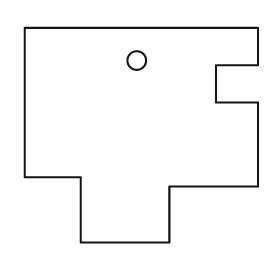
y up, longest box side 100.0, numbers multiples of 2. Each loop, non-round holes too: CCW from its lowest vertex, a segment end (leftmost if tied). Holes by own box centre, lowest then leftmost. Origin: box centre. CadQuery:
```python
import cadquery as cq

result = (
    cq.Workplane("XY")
    .moveTo(-26.0, -46.0)
    .lineTo(12.0, -46.0)
    .lineTo(12.0, -22.0)
    .lineTo(50.0, -22.0)
    .lineTo(50.0, 14.0)
    .lineTo(32.0, 14.0)
    .lineTo(32.0, 30.0)
    .lineTo(50.0, 30.0)
    .lineTo(50.0, 46.0)
    .lineTo(-50.0, 46.0)
    .lineTo(-50.0, -18.0)
    .lineTo(-26.0, -18.0)
    .close()
    .moveTo(-2.0, 32.0)
    .circle(4.0)
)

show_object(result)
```